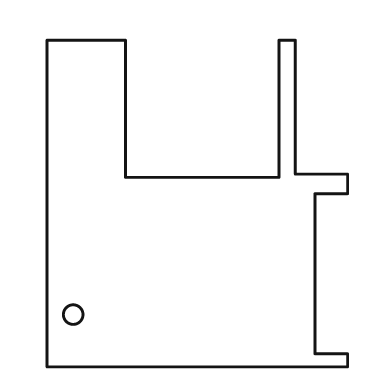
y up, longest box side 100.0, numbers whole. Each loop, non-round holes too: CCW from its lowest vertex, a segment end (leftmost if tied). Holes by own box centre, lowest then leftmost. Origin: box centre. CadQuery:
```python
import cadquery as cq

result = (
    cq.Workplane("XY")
    .moveTo(-46.0, -50.0)
    .lineTo(46.0, -50.0)
    .lineTo(46.0, -46.0)
    .lineTo(36.0, -46.0)
    .lineTo(36.0, 3.0)
    .lineTo(46.0, 3.0)
    .lineTo(46.0, 9.0)
    .lineTo(30.0, 9.0)
    .lineTo(30.0, 50.0)
    .lineTo(25.0, 50.0)
    .lineTo(25.0, 8.0)
    .lineTo(-22.0, 8.0)
    .lineTo(-22.0, 50.0)
    .lineTo(-46.0, 50.0)
    .close()
    .moveTo(-38.0, -34.0)
    .circle(3.0)
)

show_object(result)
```